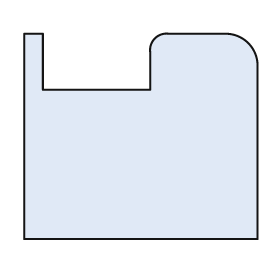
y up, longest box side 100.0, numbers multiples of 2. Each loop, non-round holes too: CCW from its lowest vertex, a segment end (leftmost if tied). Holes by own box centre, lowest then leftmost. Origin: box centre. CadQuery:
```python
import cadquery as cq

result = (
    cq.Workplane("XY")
    .moveTo(-50.0, -44.0)
    .lineTo(50.0, -44.0)
    .lineTo(50.0, 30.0)
    .threePointArc((46.0, 40.0), (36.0, 44.0))
    .lineTo(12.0, 44.0)
    .threePointArc((6.0, 42.0), (4.0, 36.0))
    .lineTo(4.0, 20.0)
    .lineTo(-42.0, 20.0)
    .lineTo(-42.0, 44.0)
    .lineTo(-50.0, 44.0)
    .close()
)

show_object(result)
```